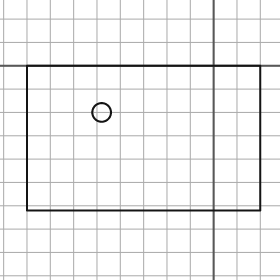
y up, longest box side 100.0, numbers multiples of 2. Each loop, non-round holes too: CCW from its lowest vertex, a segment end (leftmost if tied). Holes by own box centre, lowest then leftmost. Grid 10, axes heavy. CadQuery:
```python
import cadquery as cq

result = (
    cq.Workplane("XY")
    .moveTo(-80.0, -62.0)
    .lineTo(20.0, -62.0)
    .lineTo(20.0, 0.0)
    .lineTo(-80.0, 0.0)
    .close()
    .moveTo(-48.0, -20.0)
    .circle(4.0)
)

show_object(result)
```